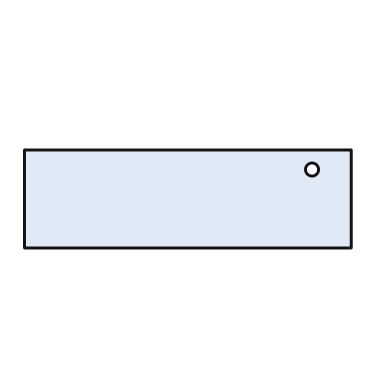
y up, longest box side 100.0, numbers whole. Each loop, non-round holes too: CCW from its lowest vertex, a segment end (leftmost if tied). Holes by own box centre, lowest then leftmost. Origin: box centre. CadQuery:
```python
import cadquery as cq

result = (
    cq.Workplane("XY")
    .moveTo(-50.0, -15.0)
    .lineTo(50.0, -15.0)
    .lineTo(50.0, 15.0)
    .lineTo(-50.0, 15.0)
    .close()
    .moveTo(38.0, 9.0)
    .circle(2.0)
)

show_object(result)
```